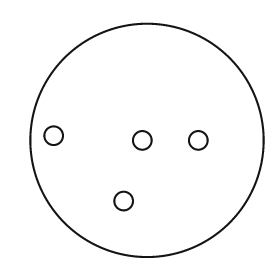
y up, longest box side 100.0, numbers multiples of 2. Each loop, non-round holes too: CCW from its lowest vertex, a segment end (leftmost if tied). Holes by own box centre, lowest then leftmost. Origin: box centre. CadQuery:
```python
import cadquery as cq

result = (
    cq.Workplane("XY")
    .moveTo(0.0, 0.0)
    .circle(50.0)
    .moveTo(-10.0, -26.0)
    .circle(4.0)
    .moveTo(-2.0, 0.0)
    .circle(4.0)
    .moveTo(22.0, 0.0)
    .circle(4.0)
    .moveTo(-40.0, 2.0)
    .circle(4.0)
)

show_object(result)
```